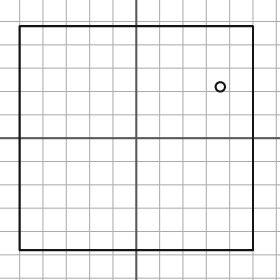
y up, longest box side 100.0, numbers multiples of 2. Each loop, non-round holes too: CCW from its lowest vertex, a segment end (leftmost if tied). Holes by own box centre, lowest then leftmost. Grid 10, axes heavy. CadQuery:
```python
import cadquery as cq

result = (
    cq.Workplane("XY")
    .moveTo(-50.0, -48.0)
    .lineTo(50.0, -48.0)
    .lineTo(50.0, 48.0)
    .lineTo(-50.0, 48.0)
    .close()
    .moveTo(36.0, 22.0)
    .circle(2.0)
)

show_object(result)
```